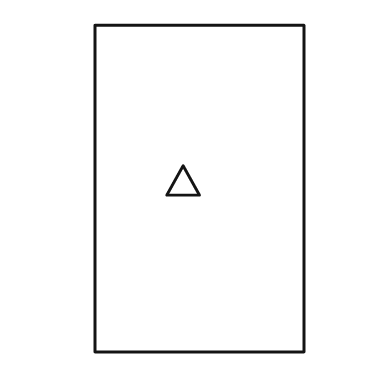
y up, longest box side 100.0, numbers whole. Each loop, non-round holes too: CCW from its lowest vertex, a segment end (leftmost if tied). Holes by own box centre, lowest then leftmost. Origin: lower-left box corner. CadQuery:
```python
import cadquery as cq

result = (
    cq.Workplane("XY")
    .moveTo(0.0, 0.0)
    .lineTo(64.0, 0.0)
    .lineTo(64.0, 100.0)
    .lineTo(0.0, 100.0)
    .close()
    .moveTo(22.0, 48.0)
    .lineTo(32.0, 48.0)
    .lineTo(27.0, 57.0)
    .close()
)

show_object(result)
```